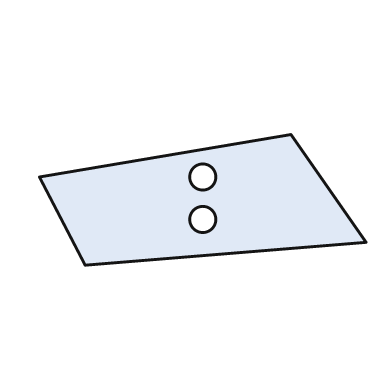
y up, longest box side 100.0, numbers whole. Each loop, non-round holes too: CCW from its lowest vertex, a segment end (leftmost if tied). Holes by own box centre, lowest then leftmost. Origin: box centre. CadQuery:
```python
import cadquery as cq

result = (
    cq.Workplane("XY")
    .moveTo(-36.0, -20.0)
    .lineTo(50.0, -13.0)
    .lineTo(27.0, 20.0)
    .lineTo(-50.0, 7.0)
    .close()
    .moveTo(0.0, -6.0)
    .circle(4.0)
    .moveTo(0.0, 7.0)
    .circle(4.0)
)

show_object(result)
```